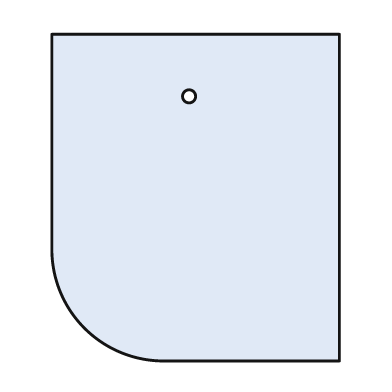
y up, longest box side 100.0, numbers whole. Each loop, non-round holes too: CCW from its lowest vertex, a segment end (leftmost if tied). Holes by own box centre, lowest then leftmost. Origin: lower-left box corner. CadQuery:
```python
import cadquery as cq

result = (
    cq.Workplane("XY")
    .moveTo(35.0, 0.0)
    .lineTo(88.0, 0.0)
    .lineTo(88.0, 100.0)
    .lineTo(0.0, 100.0)
    .lineTo(0.0, 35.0)
    .threePointArc((10.0, 10.0), (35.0, 0.0))
    .close()
    .moveTo(42.0, 81.0)
    .circle(2.0)
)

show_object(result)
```